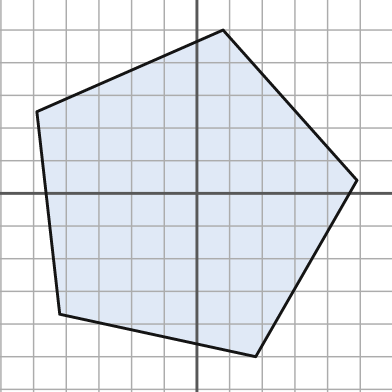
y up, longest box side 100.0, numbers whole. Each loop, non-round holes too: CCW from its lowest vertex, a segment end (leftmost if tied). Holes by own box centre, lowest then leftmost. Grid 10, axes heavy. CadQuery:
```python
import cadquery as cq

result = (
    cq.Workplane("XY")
    .moveTo(18.0, -50.0)
    .lineTo(49.0, 4.0)
    .lineTo(8.0, 50.0)
    .lineTo(-49.0, 25.0)
    .lineTo(-42.0, -37.0)
    .close()
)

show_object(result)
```